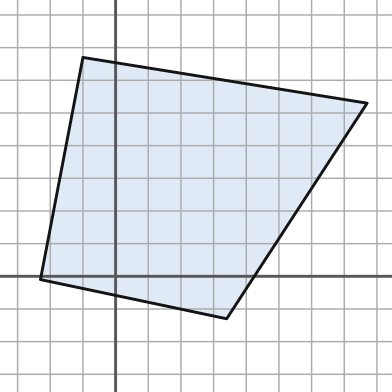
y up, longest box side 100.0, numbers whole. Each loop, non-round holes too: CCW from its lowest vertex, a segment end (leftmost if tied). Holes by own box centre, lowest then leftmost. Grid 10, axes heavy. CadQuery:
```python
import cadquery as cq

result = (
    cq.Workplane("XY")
    .moveTo(34.0, -13.0)
    .lineTo(77.0, 53.0)
    .lineTo(-10.0, 67.0)
    .lineTo(-23.0, -1.0)
    .close()
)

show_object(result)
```